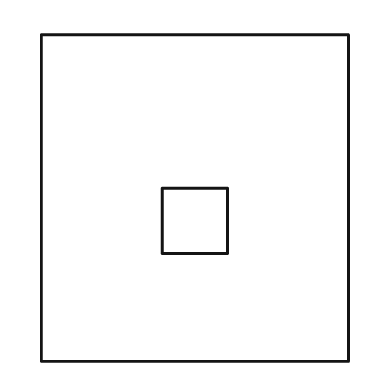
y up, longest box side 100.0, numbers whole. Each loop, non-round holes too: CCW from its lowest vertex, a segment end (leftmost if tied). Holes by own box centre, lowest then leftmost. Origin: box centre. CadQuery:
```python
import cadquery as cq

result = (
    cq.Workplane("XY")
    .moveTo(-47.0, -50.0)
    .lineTo(47.0, -50.0)
    .lineTo(47.0, 50.0)
    .lineTo(-47.0, 50.0)
    .close()
    .moveTo(-10.0, -17.0)
    .lineTo(10.0, -17.0)
    .lineTo(10.0, 3.0)
    .lineTo(-10.0, 3.0)
    .close()
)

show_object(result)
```